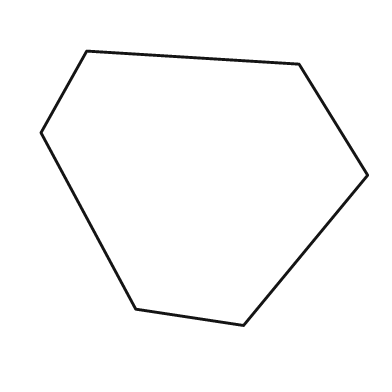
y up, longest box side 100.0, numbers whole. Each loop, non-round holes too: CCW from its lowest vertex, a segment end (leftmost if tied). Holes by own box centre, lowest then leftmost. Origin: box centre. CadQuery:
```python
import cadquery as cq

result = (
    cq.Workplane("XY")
    .moveTo(12.0, -42.0)
    .lineTo(50.0, 4.0)
    .lineTo(29.0, 38.0)
    .lineTo(-36.0, 42.0)
    .lineTo(-50.0, 17.0)
    .lineTo(-21.0, -37.0)
    .close()
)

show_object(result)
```